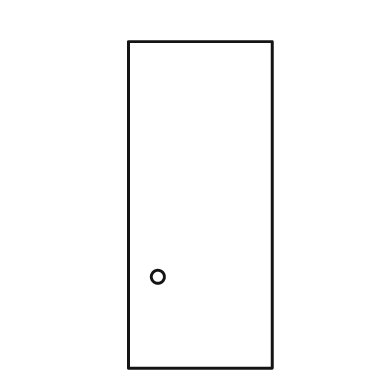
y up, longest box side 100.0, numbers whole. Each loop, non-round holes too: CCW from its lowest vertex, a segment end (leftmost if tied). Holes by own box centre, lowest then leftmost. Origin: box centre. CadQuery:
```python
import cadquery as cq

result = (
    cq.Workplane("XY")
    .moveTo(-22.0, -50.0)
    .lineTo(22.0, -50.0)
    .lineTo(22.0, 50.0)
    .lineTo(-22.0, 50.0)
    .close()
    .moveTo(-13.0, -22.0)
    .circle(2.0)
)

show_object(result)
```